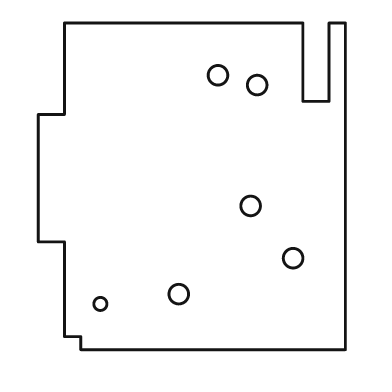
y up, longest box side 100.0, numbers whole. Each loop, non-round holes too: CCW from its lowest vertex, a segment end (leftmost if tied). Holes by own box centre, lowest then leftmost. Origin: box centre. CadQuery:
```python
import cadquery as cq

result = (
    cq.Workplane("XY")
    .moveTo(-34.0, -50.0)
    .lineTo(47.0, -50.0)
    .lineTo(47.0, 50.0)
    .lineTo(42.0, 50.0)
    .lineTo(42.0, 26.0)
    .lineTo(34.0, 26.0)
    .lineTo(34.0, 50.0)
    .lineTo(-39.0, 50.0)
    .lineTo(-39.0, 22.0)
    .lineTo(-47.0, 22.0)
    .lineTo(-47.0, -17.0)
    .lineTo(-39.0, -17.0)
    .lineTo(-39.0, -46.0)
    .lineTo(-34.0, -46.0)
    .close()
    .moveTo(-28.0, -36.0)
    .circle(2.0)
    .moveTo(-4.0, -33.0)
    .circle(3.0)
    .moveTo(31.0, -22.0)
    .circle(3.0)
    .moveTo(18.0, -6.0)
    .circle(3.0)
    .moveTo(20.0, 31.0)
    .circle(3.0)
    .moveTo(8.0, 34.0)
    .circle(3.0)
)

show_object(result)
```